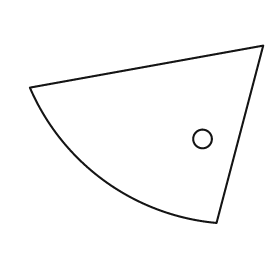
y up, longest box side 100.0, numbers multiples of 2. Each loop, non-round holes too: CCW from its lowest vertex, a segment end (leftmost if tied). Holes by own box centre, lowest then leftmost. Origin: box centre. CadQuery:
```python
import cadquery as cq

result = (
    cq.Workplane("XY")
    .moveTo(30.0, -38.0)
    .lineTo(50.0, 38.0)
    .lineTo(-50.0, 20.0)
    .threePointArc((-18.0, -20.0), (30.0, -38.0))
    .close()
    .moveTo(24.0, -2.0)
    .circle(4.0)
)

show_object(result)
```